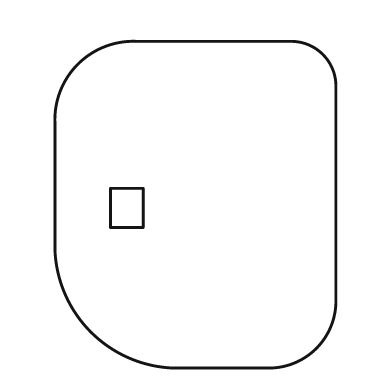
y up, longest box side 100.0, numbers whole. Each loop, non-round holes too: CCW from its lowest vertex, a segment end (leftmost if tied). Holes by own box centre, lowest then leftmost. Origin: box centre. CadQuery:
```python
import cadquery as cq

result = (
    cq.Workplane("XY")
    .moveTo(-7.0, -50.0)
    .lineTo(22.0, -50.0)
    .threePointArc((37.0, -44.0), (43.0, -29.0))
    .lineTo(43.0, 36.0)
    .threePointArc((39.0, 46.0), (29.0, 50.0))
    .lineTo(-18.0, 50.0)
    .threePointArc((-36.0, 43.0), (-43.0, 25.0))
    .lineTo(-43.0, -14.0)
    .threePointArc((-32.0, -39.0), (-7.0, -50.0))
    .close()
    .moveTo(-26.0, -7.0)
    .lineTo(-16.0, -7.0)
    .lineTo(-16.0, 5.0)
    .lineTo(-26.0, 5.0)
    .close()
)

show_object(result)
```